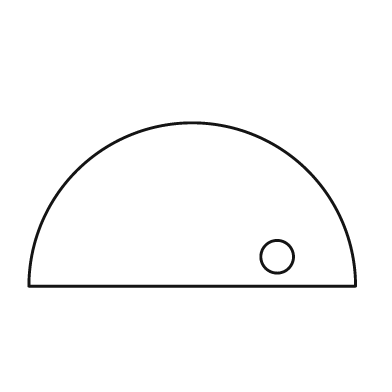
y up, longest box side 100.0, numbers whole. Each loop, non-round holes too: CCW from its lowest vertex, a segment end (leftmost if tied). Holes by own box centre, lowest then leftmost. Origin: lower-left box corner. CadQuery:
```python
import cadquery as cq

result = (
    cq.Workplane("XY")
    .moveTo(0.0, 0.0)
    .lineTo(100.0, 0.0)
    .threePointArc((50.0, 50.0), (0.0, 0.0))
    .close()
    .moveTo(76.0, 9.0)
    .circle(5.0)
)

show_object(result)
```